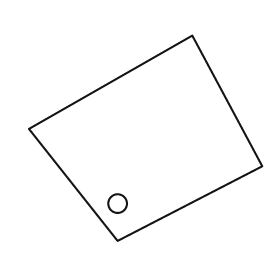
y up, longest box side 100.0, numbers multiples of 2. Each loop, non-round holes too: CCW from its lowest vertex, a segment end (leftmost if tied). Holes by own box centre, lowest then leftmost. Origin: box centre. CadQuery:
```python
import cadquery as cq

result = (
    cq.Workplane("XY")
    .moveTo(-12.0, -44.0)
    .lineTo(50.0, -12.0)
    .lineTo(20.0, 44.0)
    .lineTo(-50.0, 4.0)
    .close()
    .moveTo(-12.0, -28.0)
    .circle(4.0)
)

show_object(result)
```